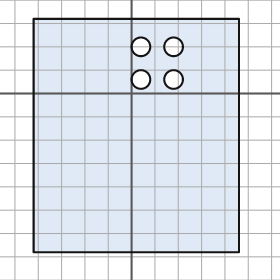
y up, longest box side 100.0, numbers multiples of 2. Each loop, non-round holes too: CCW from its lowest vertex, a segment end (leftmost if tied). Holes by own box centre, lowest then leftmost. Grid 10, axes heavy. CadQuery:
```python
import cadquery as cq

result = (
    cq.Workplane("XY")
    .moveTo(-42.0, -68.0)
    .lineTo(46.0, -68.0)
    .lineTo(46.0, 32.0)
    .lineTo(-42.0, 32.0)
    .close()
    .moveTo(4.0, 6.0)
    .circle(4.0)
    .moveTo(18.0, 6.0)
    .circle(4.0)
    .moveTo(4.0, 20.0)
    .circle(4.0)
    .moveTo(18.0, 20.0)
    .circle(4.0)
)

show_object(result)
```